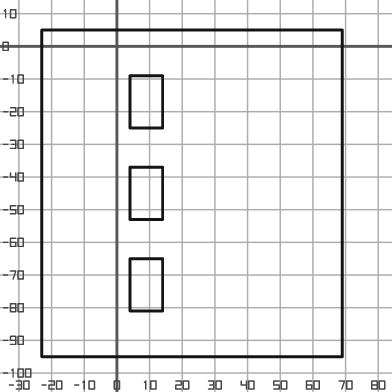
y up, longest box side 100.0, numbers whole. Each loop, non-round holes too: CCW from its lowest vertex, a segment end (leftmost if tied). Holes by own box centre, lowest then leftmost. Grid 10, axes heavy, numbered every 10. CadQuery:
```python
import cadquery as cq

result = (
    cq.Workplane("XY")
    .moveTo(-23.0, -95.0)
    .lineTo(69.0, -95.0)
    .lineTo(69.0, 5.0)
    .lineTo(-23.0, 5.0)
    .close()
    .moveTo(4.0, -81.0)
    .lineTo(14.0, -81.0)
    .lineTo(14.0, -65.0)
    .lineTo(4.0, -65.0)
    .close()
    .moveTo(4.0, -53.0)
    .lineTo(14.0, -53.0)
    .lineTo(14.0, -37.0)
    .lineTo(4.0, -37.0)
    .close()
    .moveTo(4.0, -25.0)
    .lineTo(14.0, -25.0)
    .lineTo(14.0, -9.0)
    .lineTo(4.0, -9.0)
    .close()
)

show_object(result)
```